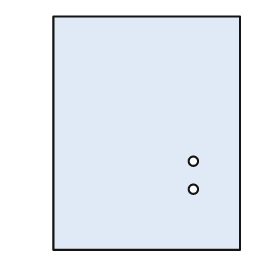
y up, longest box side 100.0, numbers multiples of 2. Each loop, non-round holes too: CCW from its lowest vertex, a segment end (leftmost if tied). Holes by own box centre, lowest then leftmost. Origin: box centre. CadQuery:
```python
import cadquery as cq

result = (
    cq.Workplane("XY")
    .moveTo(-40.0, -50.0)
    .lineTo(40.0, -50.0)
    .lineTo(40.0, 50.0)
    .lineTo(-40.0, 50.0)
    .close()
    .moveTo(20.0, -24.0)
    .circle(2.0)
    .moveTo(20.0, -12.0)
    .circle(2.0)
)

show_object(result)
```